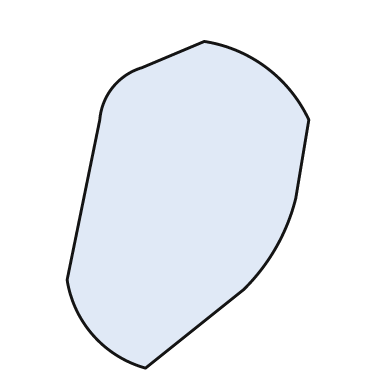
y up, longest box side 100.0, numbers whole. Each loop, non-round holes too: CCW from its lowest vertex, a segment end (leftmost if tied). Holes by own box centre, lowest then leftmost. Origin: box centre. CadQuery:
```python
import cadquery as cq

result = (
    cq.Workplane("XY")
    .moveTo(-13.0, -50.0)
    .lineTo(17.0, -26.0)
    .threePointArc((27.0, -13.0), (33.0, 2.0))
    .lineTo(37.0, 26.0)
    .threePointArc((24.0, 42.0), (5.0, 50.0))
    .lineTo(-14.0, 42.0)
    .threePointArc((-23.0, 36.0), (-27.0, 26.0))
    .lineTo(-37.0, -23.0)
    .threePointArc((-29.0, -40.0), (-13.0, -50.0))
    .close()
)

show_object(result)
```